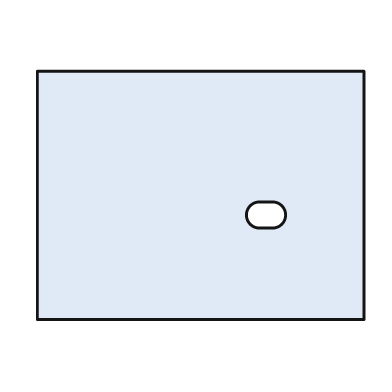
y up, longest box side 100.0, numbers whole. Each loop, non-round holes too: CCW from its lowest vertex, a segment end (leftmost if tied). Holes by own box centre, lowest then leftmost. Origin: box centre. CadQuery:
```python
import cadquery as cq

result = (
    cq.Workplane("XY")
    .moveTo(-50.0, -38.0)
    .lineTo(50.0, -38.0)
    .lineTo(50.0, 38.0)
    .lineTo(-50.0, 38.0)
    .close()
    .moveTo(18.0, -10.0)
    .lineTo(22.0, -10.0)
    .threePointArc((26.0, -6.0), (22.0, -2.0))
    .lineTo(18.0, -2.0)
    .threePointArc((14.0, -6.0), (18.0, -10.0))
    .close()
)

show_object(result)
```